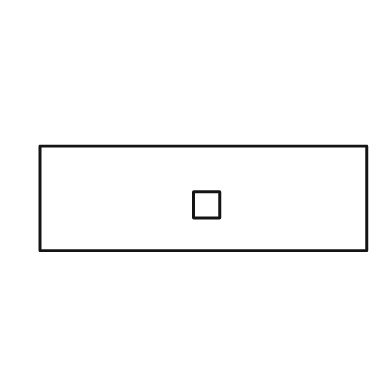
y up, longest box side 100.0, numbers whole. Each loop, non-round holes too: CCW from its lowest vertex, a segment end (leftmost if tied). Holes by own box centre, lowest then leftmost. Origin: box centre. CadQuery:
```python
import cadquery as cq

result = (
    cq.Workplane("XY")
    .moveTo(-50.0, -16.0)
    .lineTo(50.0, -16.0)
    .lineTo(50.0, 16.0)
    .lineTo(-50.0, 16.0)
    .close()
    .moveTo(-3.0, -6.0)
    .lineTo(5.0, -6.0)
    .lineTo(5.0, 2.0)
    .lineTo(-3.0, 2.0)
    .close()
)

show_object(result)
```